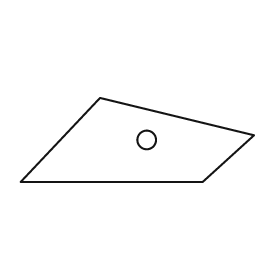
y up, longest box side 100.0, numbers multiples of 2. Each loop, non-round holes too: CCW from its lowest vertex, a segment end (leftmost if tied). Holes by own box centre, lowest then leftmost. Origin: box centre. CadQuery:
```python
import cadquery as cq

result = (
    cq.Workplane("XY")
    .moveTo(-50.0, -18.0)
    .lineTo(28.0, -18.0)
    .lineTo(50.0, 2.0)
    .lineTo(-16.0, 18.0)
    .close()
    .moveTo(4.0, 0.0)
    .circle(4.0)
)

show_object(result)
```